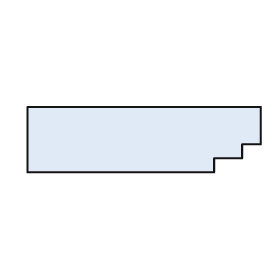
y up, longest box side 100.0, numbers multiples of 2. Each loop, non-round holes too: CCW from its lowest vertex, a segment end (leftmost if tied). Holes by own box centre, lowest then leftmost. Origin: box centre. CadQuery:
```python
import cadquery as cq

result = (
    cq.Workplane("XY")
    .moveTo(-50.0, -14.0)
    .lineTo(30.0, -14.0)
    .lineTo(30.0, -8.0)
    .lineTo(42.0, -8.0)
    .lineTo(42.0, -2.0)
    .lineTo(50.0, -2.0)
    .lineTo(50.0, 14.0)
    .lineTo(-50.0, 14.0)
    .close()
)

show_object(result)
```